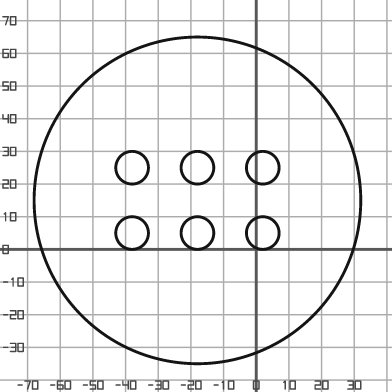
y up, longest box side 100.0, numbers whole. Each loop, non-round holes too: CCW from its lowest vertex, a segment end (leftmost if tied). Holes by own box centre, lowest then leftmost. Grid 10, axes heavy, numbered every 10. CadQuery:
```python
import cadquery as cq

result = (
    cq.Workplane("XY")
    .moveTo(-18.0, 15.0)
    .circle(50.0)
    .moveTo(-38.0, 5.0)
    .circle(5.0)
    .moveTo(-18.0, 5.0)
    .circle(5.0)
    .moveTo(2.0, 5.0)
    .circle(5.0)
    .moveTo(-38.0, 25.0)
    .circle(5.0)
    .moveTo(-18.0, 25.0)
    .circle(5.0)
    .moveTo(2.0, 25.0)
    .circle(5.0)
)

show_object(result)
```